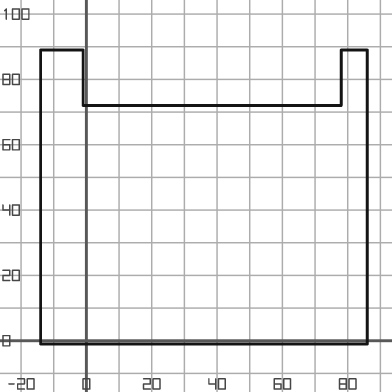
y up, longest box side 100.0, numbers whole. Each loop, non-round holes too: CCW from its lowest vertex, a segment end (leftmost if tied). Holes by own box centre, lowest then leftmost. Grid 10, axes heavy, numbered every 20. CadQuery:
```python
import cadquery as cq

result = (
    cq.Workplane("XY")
    .moveTo(-14.0, -1.0)
    .lineTo(86.0, -1.0)
    .lineTo(86.0, 89.0)
    .lineTo(78.0, 89.0)
    .lineTo(78.0, 72.0)
    .lineTo(-1.0, 72.0)
    .lineTo(-1.0, 89.0)
    .lineTo(-14.0, 89.0)
    .close()
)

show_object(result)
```